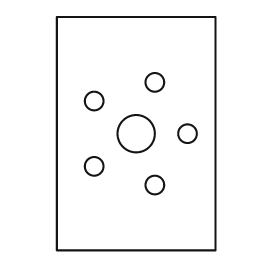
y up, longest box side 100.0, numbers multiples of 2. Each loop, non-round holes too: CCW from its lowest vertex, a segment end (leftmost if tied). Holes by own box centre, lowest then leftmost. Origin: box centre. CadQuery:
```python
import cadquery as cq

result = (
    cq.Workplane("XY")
    .moveTo(-34.0, -50.0)
    .lineTo(34.0, -50.0)
    .lineTo(34.0, 50.0)
    .lineTo(-34.0, 50.0)
    .close()
    .moveTo(8.0, -22.0)
    .circle(4.0)
    .moveTo(-18.0, -14.0)
    .circle(4.0)
    .moveTo(0.0, 0.0)
    .circle(8.0)
    .moveTo(22.0, 0.0)
    .circle(4.0)
    .moveTo(-18.0, 14.0)
    .circle(4.0)
    .moveTo(8.0, 22.0)
    .circle(4.0)
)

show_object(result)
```